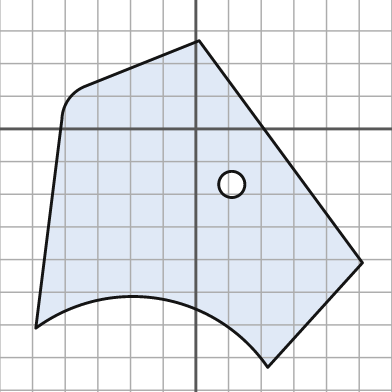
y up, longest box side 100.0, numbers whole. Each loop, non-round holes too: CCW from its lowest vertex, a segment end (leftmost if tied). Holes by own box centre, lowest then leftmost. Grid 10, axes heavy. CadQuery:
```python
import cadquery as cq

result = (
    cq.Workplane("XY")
    .moveTo(22.0, -73.0)
    .lineTo(51.0, -41.0)
    .lineTo(1.0, 27.0)
    .lineTo(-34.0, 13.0)
    .threePointArc((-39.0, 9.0), (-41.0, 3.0))
    .lineTo(-49.0, -61.0)
    .threePointArc((-11.0, -52.0), (22.0, -73.0))
    .close()
    .moveTo(11.0, -17.0)
    .circle(4.0)
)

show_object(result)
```